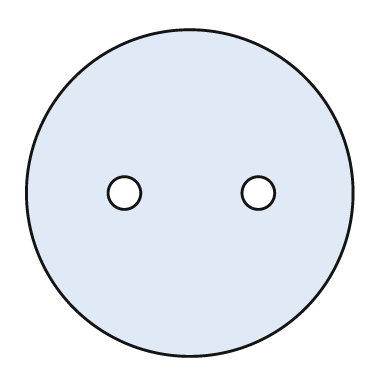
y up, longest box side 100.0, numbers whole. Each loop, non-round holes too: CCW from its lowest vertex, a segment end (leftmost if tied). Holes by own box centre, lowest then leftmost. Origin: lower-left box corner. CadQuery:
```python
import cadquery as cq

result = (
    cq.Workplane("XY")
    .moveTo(50.0, 50.0)
    .circle(50.0)
    .moveTo(30.0, 50.0)
    .circle(5.0)
    .moveTo(71.0, 50.0)
    .circle(5.0)
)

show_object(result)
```